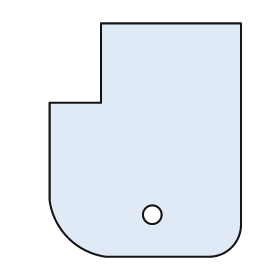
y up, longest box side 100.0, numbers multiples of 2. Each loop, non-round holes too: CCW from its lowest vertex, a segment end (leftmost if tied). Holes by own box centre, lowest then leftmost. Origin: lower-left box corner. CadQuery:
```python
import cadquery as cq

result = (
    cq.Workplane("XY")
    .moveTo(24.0, 0.0)
    .lineTo(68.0, 0.0)
    .threePointArc((78.0, 4.0), (82.0, 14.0))
    .lineTo(82.0, 100.0)
    .lineTo(22.0, 100.0)
    .lineTo(22.0, 66.0)
    .lineTo(0.0, 66.0)
    .lineTo(0.0, 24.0)
    .threePointArc((8.0, 8.0), (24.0, 0.0))
    .close()
    .moveTo(44.0, 18.0)
    .circle(4.0)
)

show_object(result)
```